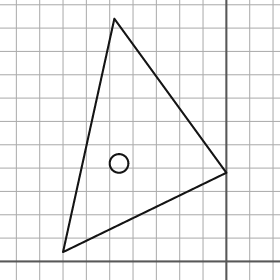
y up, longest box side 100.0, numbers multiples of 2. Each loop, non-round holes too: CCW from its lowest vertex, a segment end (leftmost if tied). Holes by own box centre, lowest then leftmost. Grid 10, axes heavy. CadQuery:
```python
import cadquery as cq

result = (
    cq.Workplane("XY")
    .moveTo(-70.0, 4.0)
    .lineTo(0.0, 38.0)
    .lineTo(-48.0, 104.0)
    .close()
    .moveTo(-46.0, 42.0)
    .circle(4.0)
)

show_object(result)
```